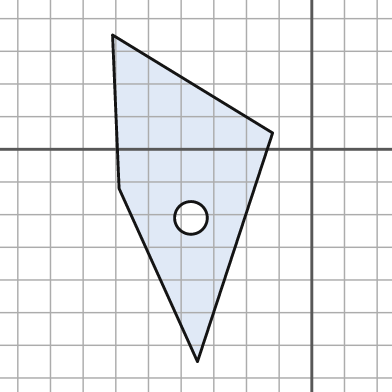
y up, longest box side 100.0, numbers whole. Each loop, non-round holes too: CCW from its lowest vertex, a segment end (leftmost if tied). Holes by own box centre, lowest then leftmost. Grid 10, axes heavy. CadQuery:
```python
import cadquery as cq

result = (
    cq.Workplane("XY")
    .moveTo(-35.0, -65.0)
    .lineTo(-12.0, 5.0)
    .lineTo(-61.0, 35.0)
    .lineTo(-59.0, -12.0)
    .close()
    .moveTo(-37.0, -21.0)
    .circle(5.0)
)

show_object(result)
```